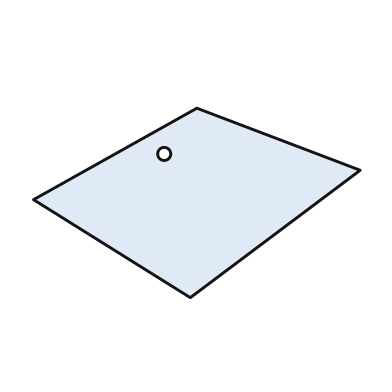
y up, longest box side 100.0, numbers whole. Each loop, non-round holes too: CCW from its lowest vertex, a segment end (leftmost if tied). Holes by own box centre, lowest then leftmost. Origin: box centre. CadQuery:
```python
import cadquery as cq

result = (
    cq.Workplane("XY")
    .moveTo(-2.0, -29.0)
    .lineTo(50.0, 10.0)
    .lineTo(0.0, 29.0)
    .lineTo(-50.0, 1.0)
    .close()
    .moveTo(-10.0, 15.0)
    .circle(2.0)
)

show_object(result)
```